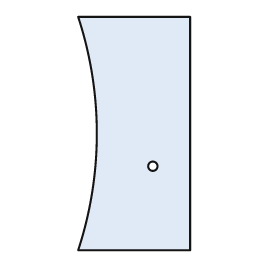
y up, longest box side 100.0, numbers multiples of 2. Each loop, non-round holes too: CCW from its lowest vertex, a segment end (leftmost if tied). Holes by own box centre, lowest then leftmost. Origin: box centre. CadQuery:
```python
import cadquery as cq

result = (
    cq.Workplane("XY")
    .moveTo(-24.0, -50.0)
    .lineTo(24.0, -50.0)
    .lineTo(24.0, 50.0)
    .lineTo(-24.0, 50.0)
    .threePointArc((-16.0, 0.0), (-24.0, -50.0))
    .close()
    .moveTo(8.0, -14.0)
    .circle(2.0)
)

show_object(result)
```